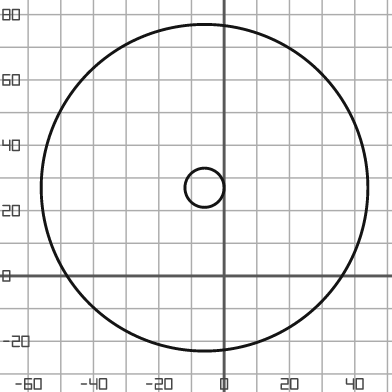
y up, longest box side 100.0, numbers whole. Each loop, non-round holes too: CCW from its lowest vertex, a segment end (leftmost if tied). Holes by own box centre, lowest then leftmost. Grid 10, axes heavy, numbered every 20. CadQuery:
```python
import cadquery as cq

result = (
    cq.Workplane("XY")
    .moveTo(-6.0, 27.0)
    .circle(50.0)
    .moveTo(-6.0, 27.0)
    .circle(6.0)
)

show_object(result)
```